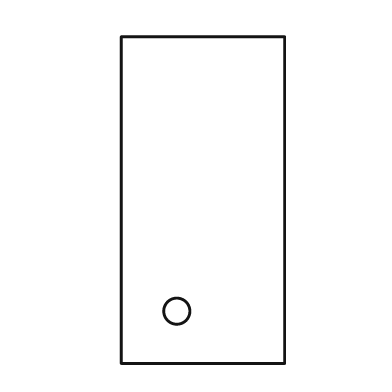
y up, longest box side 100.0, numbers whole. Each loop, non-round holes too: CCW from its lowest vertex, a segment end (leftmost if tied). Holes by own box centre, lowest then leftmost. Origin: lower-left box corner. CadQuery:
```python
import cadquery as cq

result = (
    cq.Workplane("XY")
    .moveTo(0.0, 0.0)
    .lineTo(50.0, 0.0)
    .lineTo(50.0, 100.0)
    .lineTo(0.0, 100.0)
    .close()
    .moveTo(17.0, 16.0)
    .circle(4.0)
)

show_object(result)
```